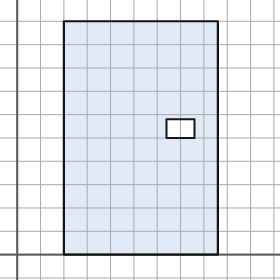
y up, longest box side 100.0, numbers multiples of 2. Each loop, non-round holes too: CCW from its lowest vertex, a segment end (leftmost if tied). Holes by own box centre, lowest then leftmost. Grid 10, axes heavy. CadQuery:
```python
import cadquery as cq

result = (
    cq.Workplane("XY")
    .moveTo(20.0, 0.0)
    .lineTo(86.0, 0.0)
    .lineTo(86.0, 100.0)
    .lineTo(20.0, 100.0)
    .close()
    .moveTo(64.0, 50.0)
    .lineTo(76.0, 50.0)
    .lineTo(76.0, 58.0)
    .lineTo(64.0, 58.0)
    .close()
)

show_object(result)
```